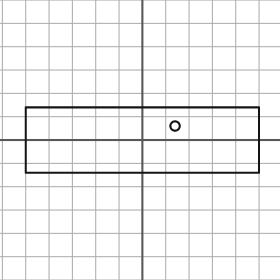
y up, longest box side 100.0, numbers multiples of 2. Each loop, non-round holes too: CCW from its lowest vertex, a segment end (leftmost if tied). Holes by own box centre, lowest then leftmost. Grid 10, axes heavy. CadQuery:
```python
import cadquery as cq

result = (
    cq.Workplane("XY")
    .moveTo(-50.0, -14.0)
    .lineTo(50.0, -14.0)
    .lineTo(50.0, 14.0)
    .lineTo(-50.0, 14.0)
    .close()
    .moveTo(14.0, 6.0)
    .circle(2.0)
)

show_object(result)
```